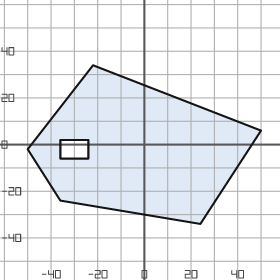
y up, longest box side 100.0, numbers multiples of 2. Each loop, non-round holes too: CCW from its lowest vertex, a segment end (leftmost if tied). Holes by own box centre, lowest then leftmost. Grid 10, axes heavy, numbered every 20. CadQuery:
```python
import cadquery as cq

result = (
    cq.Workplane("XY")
    .moveTo(24.0, -34.0)
    .lineTo(50.0, 6.0)
    .lineTo(-22.0, 34.0)
    .lineTo(-50.0, -2.0)
    .lineTo(-36.0, -24.0)
    .close()
    .moveTo(-36.0, -6.0)
    .lineTo(-24.0, -6.0)
    .lineTo(-24.0, 2.0)
    .lineTo(-36.0, 2.0)
    .close()
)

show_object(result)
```